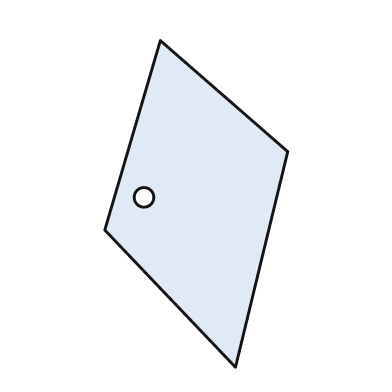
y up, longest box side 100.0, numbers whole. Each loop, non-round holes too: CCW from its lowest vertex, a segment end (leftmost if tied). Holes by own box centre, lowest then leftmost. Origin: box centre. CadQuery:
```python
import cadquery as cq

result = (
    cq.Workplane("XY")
    .moveTo(12.0, -50.0)
    .lineTo(28.0, 16.0)
    .lineTo(-11.0, 50.0)
    .lineTo(-28.0, -8.0)
    .close()
    .moveTo(-16.0, 2.0)
    .circle(3.0)
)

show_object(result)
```